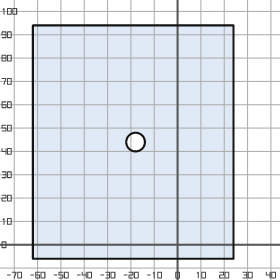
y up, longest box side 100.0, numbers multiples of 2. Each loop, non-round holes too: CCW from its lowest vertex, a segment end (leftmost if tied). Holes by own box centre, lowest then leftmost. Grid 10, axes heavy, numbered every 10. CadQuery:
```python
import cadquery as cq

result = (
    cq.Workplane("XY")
    .moveTo(-62.0, -6.0)
    .lineTo(24.0, -6.0)
    .lineTo(24.0, 94.0)
    .lineTo(-62.0, 94.0)
    .close()
    .moveTo(-18.0, 44.0)
    .circle(4.0)
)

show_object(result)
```